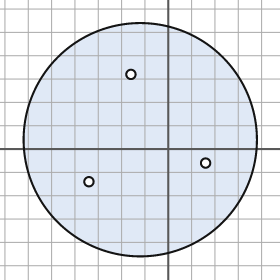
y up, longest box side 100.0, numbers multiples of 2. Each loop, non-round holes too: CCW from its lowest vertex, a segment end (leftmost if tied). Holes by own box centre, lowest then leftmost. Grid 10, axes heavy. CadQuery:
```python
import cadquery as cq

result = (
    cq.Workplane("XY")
    .moveTo(-12.0, 4.0)
    .circle(50.0)
    .moveTo(-34.0, -14.0)
    .circle(2.0)
    .moveTo(16.0, -6.0)
    .circle(2.0)
    .moveTo(-16.0, 32.0)
    .circle(2.0)
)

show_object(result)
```